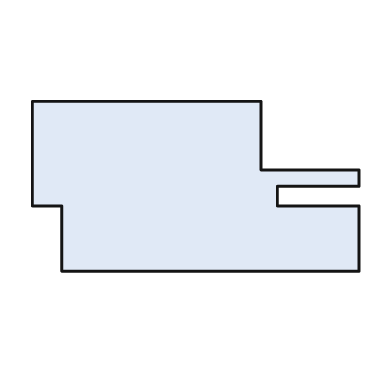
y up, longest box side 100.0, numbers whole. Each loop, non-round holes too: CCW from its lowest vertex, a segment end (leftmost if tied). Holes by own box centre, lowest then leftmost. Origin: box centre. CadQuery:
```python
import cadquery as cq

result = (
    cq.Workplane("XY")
    .moveTo(-41.0, -26.0)
    .lineTo(50.0, -26.0)
    .lineTo(50.0, -6.0)
    .lineTo(25.0, -6.0)
    .lineTo(25.0, 0.0)
    .lineTo(50.0, 0.0)
    .lineTo(50.0, 5.0)
    .lineTo(20.0, 5.0)
    .lineTo(20.0, 26.0)
    .lineTo(-50.0, 26.0)
    .lineTo(-50.0, -6.0)
    .lineTo(-41.0, -6.0)
    .close()
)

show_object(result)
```